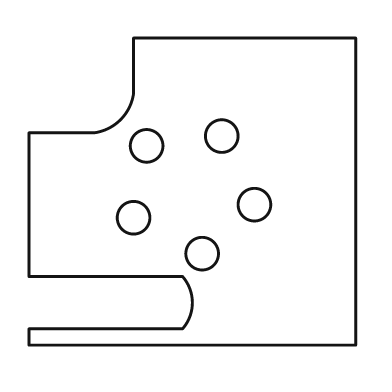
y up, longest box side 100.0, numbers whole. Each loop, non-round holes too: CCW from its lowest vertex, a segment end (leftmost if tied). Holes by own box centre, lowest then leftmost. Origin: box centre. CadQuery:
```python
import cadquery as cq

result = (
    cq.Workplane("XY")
    .moveTo(-50.0, -47.0)
    .lineTo(50.0, -47.0)
    .lineTo(50.0, 47.0)
    .lineTo(-18.0, 47.0)
    .lineTo(-18.0, 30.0)
    .threePointArc((-22.0, 22.0), (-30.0, 18.0))
    .lineTo(-50.0, 18.0)
    .lineTo(-50.0, -26.0)
    .lineTo(-3.0, -26.0)
    .threePointArc((0.0, -34.0), (-3.0, -42.0))
    .lineTo(-50.0, -42.0)
    .close()
    .moveTo(3.0, -19.0)
    .circle(5.0)
    .moveTo(-18.0, -8.0)
    .circle(5.0)
    .moveTo(19.0, -4.0)
    .circle(5.0)
    .moveTo(-14.0, 14.0)
    .circle(5.0)
    .moveTo(9.0, 17.0)
    .circle(5.0)
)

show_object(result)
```